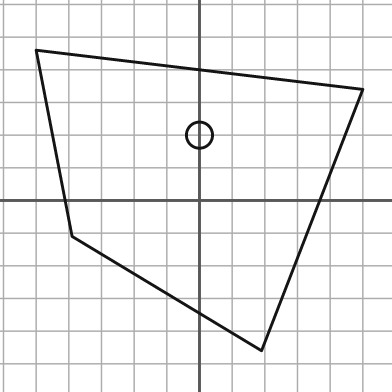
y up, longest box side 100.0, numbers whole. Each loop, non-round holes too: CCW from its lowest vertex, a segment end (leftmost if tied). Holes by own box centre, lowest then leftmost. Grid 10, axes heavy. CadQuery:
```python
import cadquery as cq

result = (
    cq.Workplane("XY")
    .moveTo(19.0, -46.0)
    .lineTo(50.0, 34.0)
    .lineTo(-50.0, 46.0)
    .lineTo(-39.0, -11.0)
    .close()
    .moveTo(0.0, 20.0)
    .circle(4.0)
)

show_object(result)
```